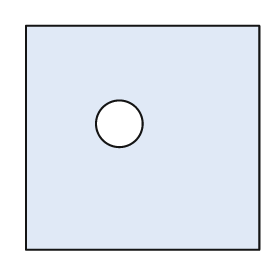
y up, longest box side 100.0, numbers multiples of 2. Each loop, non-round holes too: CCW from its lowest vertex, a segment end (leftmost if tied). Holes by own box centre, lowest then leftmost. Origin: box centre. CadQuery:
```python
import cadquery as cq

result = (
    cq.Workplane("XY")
    .moveTo(-50.0, -48.0)
    .lineTo(50.0, -48.0)
    .lineTo(50.0, 48.0)
    .lineTo(-50.0, 48.0)
    .close()
    .moveTo(-10.0, 6.0)
    .circle(10.0)
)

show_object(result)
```